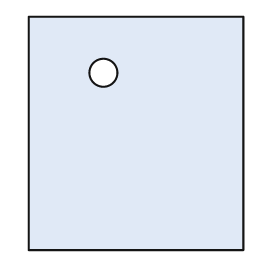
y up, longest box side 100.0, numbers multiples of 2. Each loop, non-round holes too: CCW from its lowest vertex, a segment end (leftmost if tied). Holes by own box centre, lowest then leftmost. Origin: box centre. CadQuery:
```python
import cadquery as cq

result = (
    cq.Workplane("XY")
    .moveTo(-46.0, -50.0)
    .lineTo(46.0, -50.0)
    .lineTo(46.0, 50.0)
    .lineTo(-46.0, 50.0)
    .close()
    .moveTo(-14.0, 26.0)
    .circle(6.0)
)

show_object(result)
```